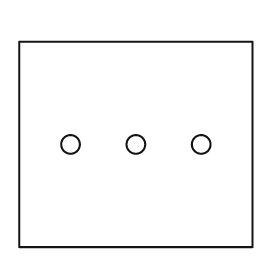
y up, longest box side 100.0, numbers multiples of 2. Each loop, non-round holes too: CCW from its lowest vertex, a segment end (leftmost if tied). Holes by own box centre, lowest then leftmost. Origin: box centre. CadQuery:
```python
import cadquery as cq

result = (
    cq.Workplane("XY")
    .moveTo(-50.0, -44.0)
    .lineTo(50.0, -44.0)
    .lineTo(50.0, 44.0)
    .lineTo(-50.0, 44.0)
    .close()
    .moveTo(-28.0, 0.0)
    .circle(4.0)
    .moveTo(0.0, 0.0)
    .circle(4.0)
    .moveTo(28.0, 0.0)
    .circle(4.0)
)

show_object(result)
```